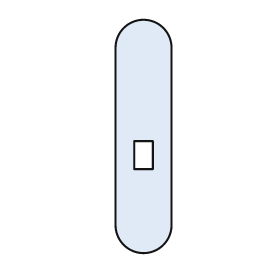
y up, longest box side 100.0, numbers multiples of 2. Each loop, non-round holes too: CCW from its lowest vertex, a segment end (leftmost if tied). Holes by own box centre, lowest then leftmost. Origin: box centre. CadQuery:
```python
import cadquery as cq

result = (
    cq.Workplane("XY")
    .moveTo(-12.0, -38.0)
    .threePointArc((0.0, -50.0), (12.0, -38.0))
    .lineTo(12.0, 38.0)
    .threePointArc((0.0, 50.0), (-12.0, 38.0))
    .close()
    .moveTo(-4.0, -14.0)
    .lineTo(4.0, -14.0)
    .lineTo(4.0, -2.0)
    .lineTo(-4.0, -2.0)
    .close()
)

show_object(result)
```